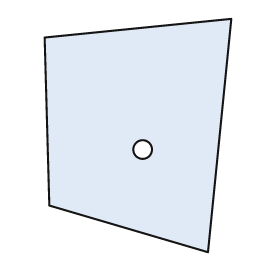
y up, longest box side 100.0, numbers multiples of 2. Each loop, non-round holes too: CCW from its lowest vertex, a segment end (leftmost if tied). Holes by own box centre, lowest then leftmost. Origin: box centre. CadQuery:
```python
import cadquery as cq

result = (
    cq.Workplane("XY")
    .moveTo(30.0, -50.0)
    .lineTo(40.0, 50.0)
    .lineTo(-40.0, 42.0)
    .lineTo(-38.0, -30.0)
    .close()
    .moveTo(2.0, -6.0)
    .circle(4.0)
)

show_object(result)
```